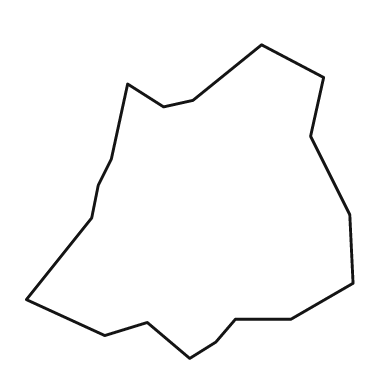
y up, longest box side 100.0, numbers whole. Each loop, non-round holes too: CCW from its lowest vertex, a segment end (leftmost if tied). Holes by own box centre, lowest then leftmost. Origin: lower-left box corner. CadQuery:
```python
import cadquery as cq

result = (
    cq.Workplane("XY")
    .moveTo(50.0, 0.0)
    .lineTo(58.0, 5.0)
    .lineTo(64.0, 12.0)
    .lineTo(81.0, 12.0)
    .lineTo(100.0, 23.0)
    .lineTo(99.0, 44.0)
    .lineTo(87.0, 68.0)
    .lineTo(91.0, 86.0)
    .lineTo(72.0, 96.0)
    .lineTo(51.0, 79.0)
    .lineTo(42.0, 77.0)
    .lineTo(31.0, 84.0)
    .lineTo(26.0, 61.0)
    .lineTo(22.0, 53.0)
    .lineTo(20.0, 43.0)
    .lineTo(0.0, 18.0)
    .lineTo(24.0, 7.0)
    .lineTo(37.0, 11.0)
    .close()
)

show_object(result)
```